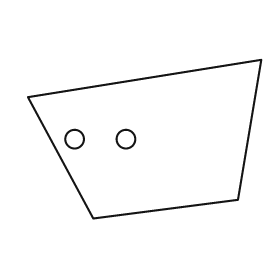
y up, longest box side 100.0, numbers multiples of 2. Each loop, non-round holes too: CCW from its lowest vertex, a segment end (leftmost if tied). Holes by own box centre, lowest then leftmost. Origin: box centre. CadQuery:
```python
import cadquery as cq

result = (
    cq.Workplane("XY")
    .moveTo(-22.0, -34.0)
    .lineTo(40.0, -26.0)
    .lineTo(50.0, 34.0)
    .lineTo(-50.0, 18.0)
    .close()
    .moveTo(-30.0, 0.0)
    .circle(4.0)
    .moveTo(-8.0, 0.0)
    .circle(4.0)
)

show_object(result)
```